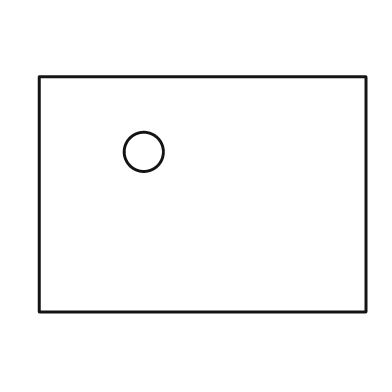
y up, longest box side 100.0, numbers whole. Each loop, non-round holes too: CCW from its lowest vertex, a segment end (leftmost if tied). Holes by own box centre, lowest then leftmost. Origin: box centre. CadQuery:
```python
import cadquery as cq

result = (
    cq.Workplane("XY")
    .moveTo(-50.0, -36.0)
    .lineTo(50.0, -36.0)
    .lineTo(50.0, 36.0)
    .lineTo(-50.0, 36.0)
    .close()
    .moveTo(-18.0, 13.0)
    .circle(6.0)
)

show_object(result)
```